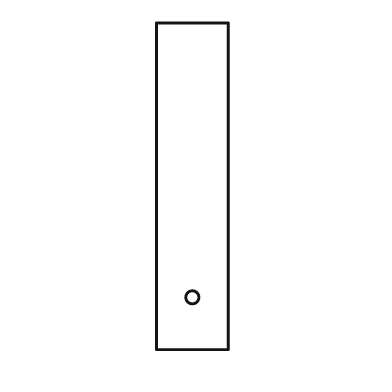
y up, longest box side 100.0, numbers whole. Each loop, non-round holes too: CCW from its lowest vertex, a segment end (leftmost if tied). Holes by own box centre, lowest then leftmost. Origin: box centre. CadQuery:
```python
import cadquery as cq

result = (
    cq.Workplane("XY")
    .moveTo(-11.0, -50.0)
    .lineTo(11.0, -50.0)
    .lineTo(11.0, 50.0)
    .lineTo(-11.0, 50.0)
    .close()
    .moveTo(0.0, -34.0)
    .circle(2.0)
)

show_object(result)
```